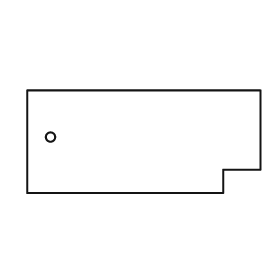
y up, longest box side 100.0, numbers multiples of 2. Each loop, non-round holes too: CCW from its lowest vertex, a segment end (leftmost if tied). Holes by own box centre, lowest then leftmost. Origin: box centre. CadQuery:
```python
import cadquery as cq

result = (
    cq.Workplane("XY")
    .moveTo(-50.0, -22.0)
    .lineTo(34.0, -22.0)
    .lineTo(34.0, -12.0)
    .lineTo(50.0, -12.0)
    .lineTo(50.0, 22.0)
    .lineTo(-50.0, 22.0)
    .close()
    .moveTo(-40.0, 2.0)
    .circle(2.0)
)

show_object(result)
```